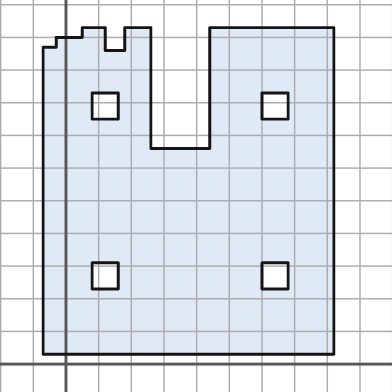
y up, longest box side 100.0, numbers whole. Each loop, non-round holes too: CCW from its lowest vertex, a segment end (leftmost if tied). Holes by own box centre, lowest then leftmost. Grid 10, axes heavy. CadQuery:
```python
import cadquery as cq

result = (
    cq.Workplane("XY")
    .moveTo(-7.0, 3.0)
    .lineTo(82.0, 3.0)
    .lineTo(82.0, 103.0)
    .lineTo(44.0, 103.0)
    .lineTo(44.0, 66.0)
    .lineTo(26.0, 66.0)
    .lineTo(26.0, 103.0)
    .lineTo(18.0, 103.0)
    .lineTo(18.0, 96.0)
    .lineTo(12.0, 96.0)
    .lineTo(12.0, 103.0)
    .lineTo(5.0, 103.0)
    .lineTo(5.0, 100.0)
    .lineTo(-3.0, 100.0)
    .lineTo(-3.0, 97.0)
    .lineTo(-7.0, 97.0)
    .close()
    .moveTo(8.0, 23.0)
    .lineTo(16.0, 23.0)
    .lineTo(16.0, 31.0)
    .lineTo(8.0, 31.0)
    .close()
    .moveTo(60.0, 23.0)
    .lineTo(68.0, 23.0)
    .lineTo(68.0, 31.0)
    .lineTo(60.0, 31.0)
    .close()
    .moveTo(8.0, 75.0)
    .lineTo(16.0, 75.0)
    .lineTo(16.0, 83.0)
    .lineTo(8.0, 83.0)
    .close()
    .moveTo(60.0, 75.0)
    .lineTo(68.0, 75.0)
    .lineTo(68.0, 83.0)
    .lineTo(60.0, 83.0)
    .close()
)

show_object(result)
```